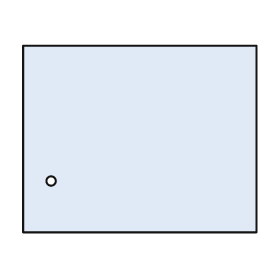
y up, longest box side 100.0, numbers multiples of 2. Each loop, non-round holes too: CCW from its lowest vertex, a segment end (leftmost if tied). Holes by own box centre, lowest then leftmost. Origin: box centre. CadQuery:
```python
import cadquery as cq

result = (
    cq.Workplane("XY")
    .moveTo(-50.0, -40.0)
    .lineTo(50.0, -40.0)
    .lineTo(50.0, 40.0)
    .lineTo(-50.0, 40.0)
    .close()
    .moveTo(-38.0, -18.0)
    .circle(2.0)
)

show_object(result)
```